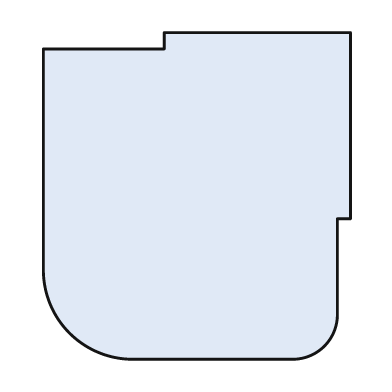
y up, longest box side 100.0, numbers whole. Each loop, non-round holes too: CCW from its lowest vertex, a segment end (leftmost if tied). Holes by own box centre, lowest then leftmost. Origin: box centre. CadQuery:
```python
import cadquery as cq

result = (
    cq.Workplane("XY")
    .moveTo(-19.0, -50.0)
    .lineTo(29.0, -50.0)
    .threePointArc((39.0, -46.0), (43.0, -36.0))
    .lineTo(43.0, -7.0)
    .lineTo(47.0, -7.0)
    .lineTo(47.0, 50.0)
    .lineTo(-10.0, 50.0)
    .lineTo(-10.0, 45.0)
    .lineTo(-47.0, 45.0)
    .lineTo(-47.0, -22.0)
    .threePointArc((-39.0, -42.0), (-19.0, -50.0))
    .close()
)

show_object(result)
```